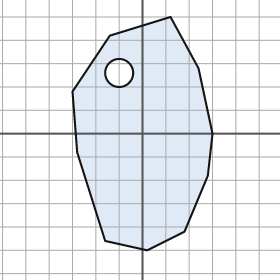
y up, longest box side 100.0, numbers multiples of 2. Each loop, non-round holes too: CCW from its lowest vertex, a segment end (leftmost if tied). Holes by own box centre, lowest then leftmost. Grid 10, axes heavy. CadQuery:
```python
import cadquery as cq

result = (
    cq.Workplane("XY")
    .moveTo(2.0, -50.0)
    .lineTo(18.0, -42.0)
    .lineTo(28.0, -18.0)
    .lineTo(30.0, 0.0)
    .lineTo(24.0, 28.0)
    .lineTo(12.0, 50.0)
    .lineTo(-14.0, 42.0)
    .lineTo(-30.0, 18.0)
    .lineTo(-28.0, -8.0)
    .lineTo(-16.0, -46.0)
    .close()
    .moveTo(-10.0, 26.0)
    .circle(6.0)
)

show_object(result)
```